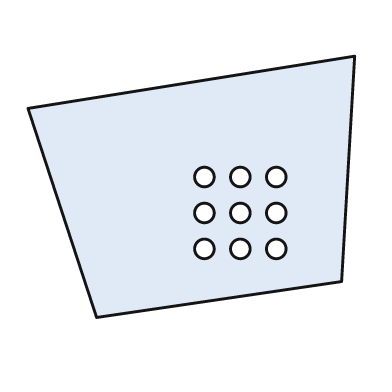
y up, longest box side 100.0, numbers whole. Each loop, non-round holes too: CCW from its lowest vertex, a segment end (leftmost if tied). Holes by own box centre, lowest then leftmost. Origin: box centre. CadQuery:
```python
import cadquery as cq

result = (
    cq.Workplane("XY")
    .moveTo(-29.0, -40.0)
    .lineTo(46.0, -29.0)
    .lineTo(50.0, 40.0)
    .lineTo(-50.0, 24.0)
    .close()
    .moveTo(4.0, -19.0)
    .circle(3.0)
    .moveTo(15.0, -19.0)
    .circle(3.0)
    .moveTo(26.0, -19.0)
    .circle(3.0)
    .moveTo(4.0, -8.0)
    .circle(3.0)
    .moveTo(15.0, -8.0)
    .circle(3.0)
    .moveTo(26.0, -8.0)
    .circle(3.0)
    .moveTo(4.0, 3.0)
    .circle(3.0)
    .moveTo(15.0, 3.0)
    .circle(3.0)
    .moveTo(26.0, 3.0)
    .circle(3.0)
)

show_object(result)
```